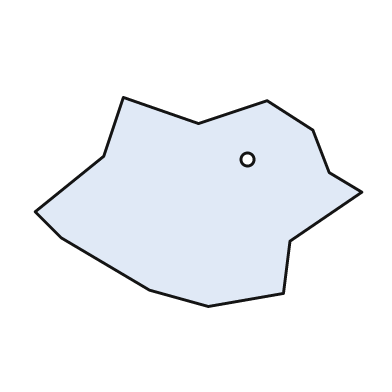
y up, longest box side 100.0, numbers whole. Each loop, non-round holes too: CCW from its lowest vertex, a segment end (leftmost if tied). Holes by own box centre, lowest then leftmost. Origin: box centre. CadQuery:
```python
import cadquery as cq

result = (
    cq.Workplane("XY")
    .moveTo(3.0, -32.0)
    .lineTo(26.0, -28.0)
    .lineTo(28.0, -12.0)
    .lineTo(50.0, 3.0)
    .lineTo(40.0, 9.0)
    .lineTo(35.0, 22.0)
    .lineTo(21.0, 31.0)
    .lineTo(0.0, 24.0)
    .lineTo(-23.0, 32.0)
    .lineTo(-29.0, 14.0)
    .lineTo(-50.0, -3.0)
    .lineTo(-42.0, -11.0)
    .lineTo(-15.0, -27.0)
    .close()
    .moveTo(15.0, 13.0)
    .circle(2.0)
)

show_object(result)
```